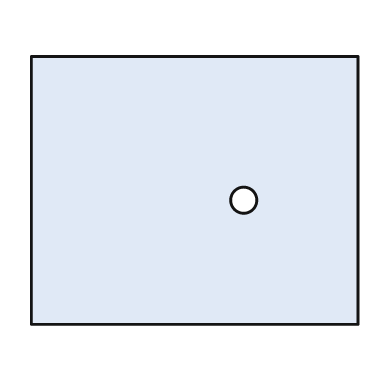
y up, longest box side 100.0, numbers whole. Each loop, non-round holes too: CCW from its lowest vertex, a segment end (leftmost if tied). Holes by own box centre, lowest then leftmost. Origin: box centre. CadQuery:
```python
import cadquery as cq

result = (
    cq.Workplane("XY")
    .moveTo(-50.0, -41.0)
    .lineTo(50.0, -41.0)
    .lineTo(50.0, 41.0)
    .lineTo(-50.0, 41.0)
    .close()
    .moveTo(15.0, -3.0)
    .circle(4.0)
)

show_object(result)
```